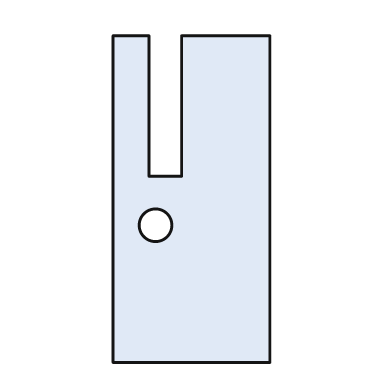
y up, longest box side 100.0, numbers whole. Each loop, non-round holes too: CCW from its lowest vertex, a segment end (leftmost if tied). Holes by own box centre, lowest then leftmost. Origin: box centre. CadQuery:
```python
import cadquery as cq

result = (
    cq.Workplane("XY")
    .moveTo(-24.0, -50.0)
    .lineTo(24.0, -50.0)
    .lineTo(24.0, 50.0)
    .lineTo(-3.0, 50.0)
    .lineTo(-3.0, 7.0)
    .lineTo(-13.0, 7.0)
    .lineTo(-13.0, 50.0)
    .lineTo(-24.0, 50.0)
    .close()
    .moveTo(-11.0, -8.0)
    .circle(5.0)
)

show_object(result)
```